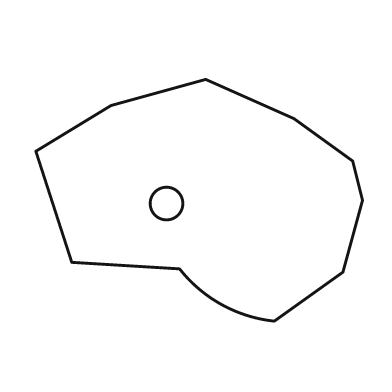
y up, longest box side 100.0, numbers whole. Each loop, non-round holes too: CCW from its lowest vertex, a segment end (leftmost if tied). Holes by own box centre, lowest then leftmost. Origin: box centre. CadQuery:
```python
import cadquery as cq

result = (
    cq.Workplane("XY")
    .moveTo(23.0, -37.0)
    .lineTo(44.0, -22.0)
    .lineTo(50.0, 0.0)
    .lineTo(47.0, 12.0)
    .lineTo(29.0, 25.0)
    .lineTo(2.0, 37.0)
    .lineTo(-27.0, 29.0)
    .lineTo(-50.0, 15.0)
    .lineTo(-39.0, -19.0)
    .lineTo(-6.0, -21.0)
    .threePointArc((7.0, -32.0), (23.0, -37.0))
    .close()
    .moveTo(-10.0, -1.0)
    .circle(5.0)
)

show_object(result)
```